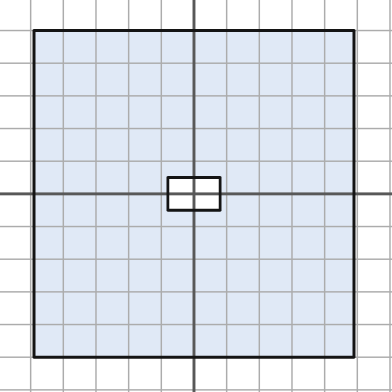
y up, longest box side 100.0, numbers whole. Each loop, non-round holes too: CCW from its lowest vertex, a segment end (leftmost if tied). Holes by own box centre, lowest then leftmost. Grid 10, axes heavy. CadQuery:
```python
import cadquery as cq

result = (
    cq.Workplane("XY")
    .moveTo(-49.0, -50.0)
    .lineTo(49.0, -50.0)
    .lineTo(49.0, 50.0)
    .lineTo(-49.0, 50.0)
    .close()
    .moveTo(-8.0, -5.0)
    .lineTo(8.0, -5.0)
    .lineTo(8.0, 5.0)
    .lineTo(-8.0, 5.0)
    .close()
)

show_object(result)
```